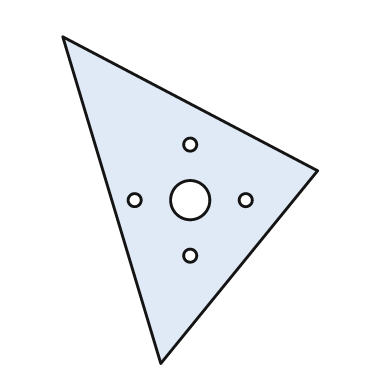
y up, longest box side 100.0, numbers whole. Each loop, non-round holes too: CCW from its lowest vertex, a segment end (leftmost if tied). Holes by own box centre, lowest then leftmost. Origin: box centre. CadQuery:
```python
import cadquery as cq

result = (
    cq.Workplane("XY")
    .moveTo(-9.0, -50.0)
    .lineTo(39.0, 9.0)
    .lineTo(-39.0, 50.0)
    .close()
    .moveTo(0.0, -17.0)
    .circle(2.0)
    .moveTo(-17.0, 0.0)
    .circle(2.0)
    .moveTo(0.0, 0.0)
    .circle(6.0)
    .moveTo(17.0, 0.0)
    .circle(2.0)
    .moveTo(0.0, 17.0)
    .circle(2.0)
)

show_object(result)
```